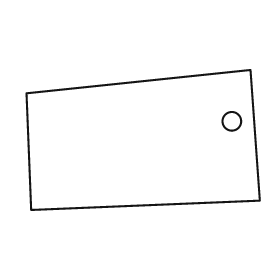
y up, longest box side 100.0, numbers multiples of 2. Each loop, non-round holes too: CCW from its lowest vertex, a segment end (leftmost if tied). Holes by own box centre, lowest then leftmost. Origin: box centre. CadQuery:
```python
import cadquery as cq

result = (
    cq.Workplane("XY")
    .moveTo(-48.0, -30.0)
    .lineTo(50.0, -26.0)
    .lineTo(46.0, 30.0)
    .lineTo(-50.0, 20.0)
    .close()
    .moveTo(38.0, 8.0)
    .circle(4.0)
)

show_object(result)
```